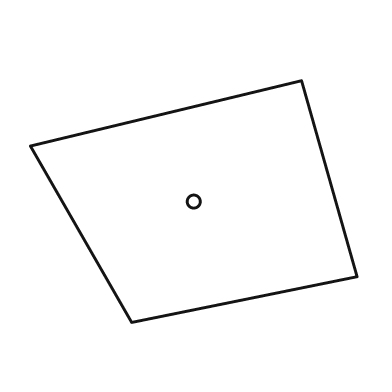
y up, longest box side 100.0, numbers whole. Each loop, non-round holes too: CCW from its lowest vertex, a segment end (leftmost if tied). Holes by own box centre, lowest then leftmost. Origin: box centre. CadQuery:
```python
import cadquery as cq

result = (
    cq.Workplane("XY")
    .moveTo(-19.0, -37.0)
    .lineTo(50.0, -23.0)
    .lineTo(33.0, 37.0)
    .lineTo(-50.0, 17.0)
    .close()
    .moveTo(0.0, 0.0)
    .circle(2.0)
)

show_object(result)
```